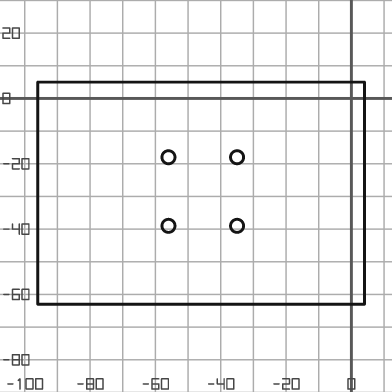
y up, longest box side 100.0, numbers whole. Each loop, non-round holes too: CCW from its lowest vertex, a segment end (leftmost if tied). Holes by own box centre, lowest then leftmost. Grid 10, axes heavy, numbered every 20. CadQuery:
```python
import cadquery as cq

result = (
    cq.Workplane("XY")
    .moveTo(-96.0, -63.0)
    .lineTo(4.0, -63.0)
    .lineTo(4.0, 5.0)
    .lineTo(-96.0, 5.0)
    .close()
    .moveTo(-56.0, -39.0)
    .circle(2.0)
    .moveTo(-35.0, -39.0)
    .circle(2.0)
    .moveTo(-56.0, -18.0)
    .circle(2.0)
    .moveTo(-35.0, -18.0)
    .circle(2.0)
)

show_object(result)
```